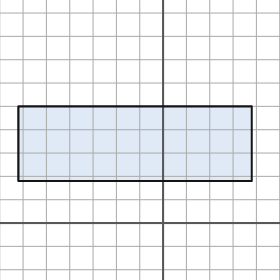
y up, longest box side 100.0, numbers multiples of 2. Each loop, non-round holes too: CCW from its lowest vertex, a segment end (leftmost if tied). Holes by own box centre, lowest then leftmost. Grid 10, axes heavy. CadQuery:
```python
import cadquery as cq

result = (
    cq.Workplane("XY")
    .moveTo(-62.0, 18.0)
    .lineTo(38.0, 18.0)
    .lineTo(38.0, 50.0)
    .lineTo(-62.0, 50.0)
    .close()
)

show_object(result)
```